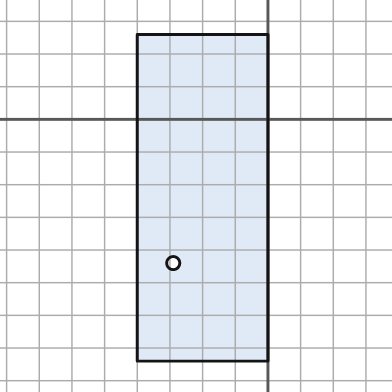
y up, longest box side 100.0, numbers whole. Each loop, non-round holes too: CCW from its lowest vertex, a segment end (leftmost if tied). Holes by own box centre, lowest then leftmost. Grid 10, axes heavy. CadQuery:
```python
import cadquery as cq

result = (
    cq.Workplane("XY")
    .moveTo(-40.0, -74.0)
    .lineTo(0.0, -74.0)
    .lineTo(0.0, 26.0)
    .lineTo(-40.0, 26.0)
    .close()
    .moveTo(-29.0, -44.0)
    .circle(2.0)
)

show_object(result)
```